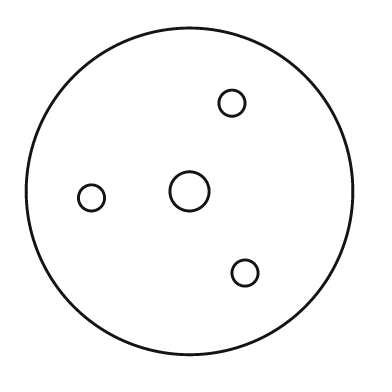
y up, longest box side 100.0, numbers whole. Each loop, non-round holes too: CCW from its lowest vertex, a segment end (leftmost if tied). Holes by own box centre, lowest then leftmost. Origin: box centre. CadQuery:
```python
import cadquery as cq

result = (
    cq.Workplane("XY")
    .moveTo(0.0, 0.0)
    .circle(50.0)
    .moveTo(17.0, -25.0)
    .circle(4.0)
    .moveTo(-30.0, -2.0)
    .circle(4.0)
    .moveTo(0.0, 0.0)
    .circle(6.0)
    .moveTo(13.0, 27.0)
    .circle(4.0)
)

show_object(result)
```